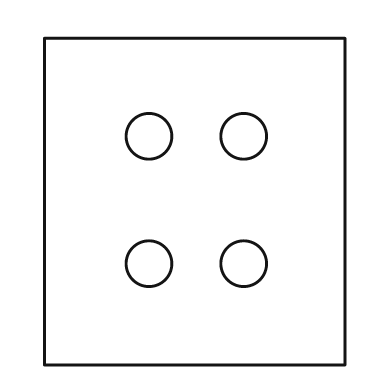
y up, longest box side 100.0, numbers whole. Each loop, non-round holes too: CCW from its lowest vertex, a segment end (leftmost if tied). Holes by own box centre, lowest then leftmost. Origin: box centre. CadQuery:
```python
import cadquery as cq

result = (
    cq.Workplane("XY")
    .moveTo(-46.0, -50.0)
    .lineTo(46.0, -50.0)
    .lineTo(46.0, 50.0)
    .lineTo(-46.0, 50.0)
    .close()
    .moveTo(-14.0, -19.0)
    .circle(7.0)
    .moveTo(15.0, -19.0)
    .circle(7.0)
    .moveTo(-14.0, 20.0)
    .circle(7.0)
    .moveTo(15.0, 20.0)
    .circle(7.0)
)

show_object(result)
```